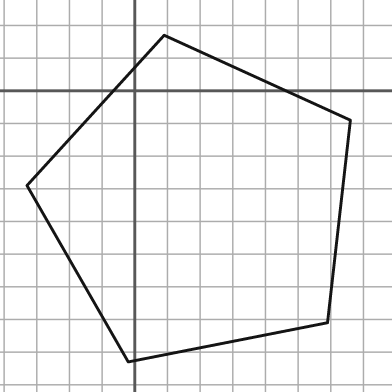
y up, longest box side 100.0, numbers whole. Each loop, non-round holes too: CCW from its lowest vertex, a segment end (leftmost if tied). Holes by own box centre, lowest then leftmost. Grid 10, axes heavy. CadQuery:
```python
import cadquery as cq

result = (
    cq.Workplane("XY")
    .moveTo(-2.0, -83.0)
    .lineTo(59.0, -71.0)
    .lineTo(66.0, -9.0)
    .lineTo(9.0, 17.0)
    .lineTo(-33.0, -29.0)
    .close()
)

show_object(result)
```